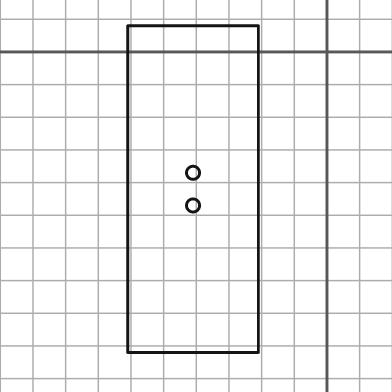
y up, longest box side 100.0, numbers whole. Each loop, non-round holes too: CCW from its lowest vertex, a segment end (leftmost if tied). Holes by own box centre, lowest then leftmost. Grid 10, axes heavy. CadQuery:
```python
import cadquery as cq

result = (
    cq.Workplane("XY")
    .moveTo(-61.0, -92.0)
    .lineTo(-21.0, -92.0)
    .lineTo(-21.0, 8.0)
    .lineTo(-61.0, 8.0)
    .close()
    .moveTo(-41.0, -47.0)
    .circle(2.0)
    .moveTo(-41.0, -37.0)
    .circle(2.0)
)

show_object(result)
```